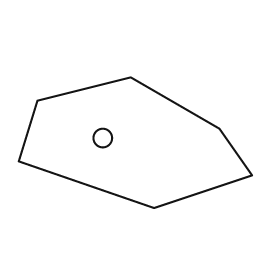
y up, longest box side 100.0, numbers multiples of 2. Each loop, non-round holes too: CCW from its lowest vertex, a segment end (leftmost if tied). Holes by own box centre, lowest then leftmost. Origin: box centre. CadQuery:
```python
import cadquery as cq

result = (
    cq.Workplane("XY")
    .moveTo(8.0, -28.0)
    .lineTo(50.0, -14.0)
    .lineTo(36.0, 6.0)
    .lineTo(-2.0, 28.0)
    .lineTo(-42.0, 18.0)
    .lineTo(-50.0, -8.0)
    .close()
    .moveTo(-14.0, 2.0)
    .circle(4.0)
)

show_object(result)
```